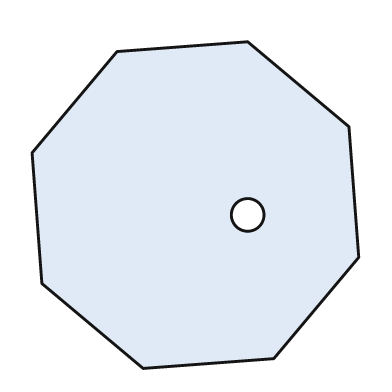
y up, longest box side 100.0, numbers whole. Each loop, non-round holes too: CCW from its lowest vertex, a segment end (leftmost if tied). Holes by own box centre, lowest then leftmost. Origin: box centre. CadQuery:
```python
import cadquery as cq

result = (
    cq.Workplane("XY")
    .moveTo(-16.0, -50.0)
    .lineTo(24.0, -47.0)
    .lineTo(50.0, -16.0)
    .lineTo(47.0, 24.0)
    .lineTo(16.0, 50.0)
    .lineTo(-24.0, 47.0)
    .lineTo(-50.0, 16.0)
    .lineTo(-47.0, -24.0)
    .close()
    .moveTo(16.0, -3.0)
    .circle(5.0)
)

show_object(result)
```